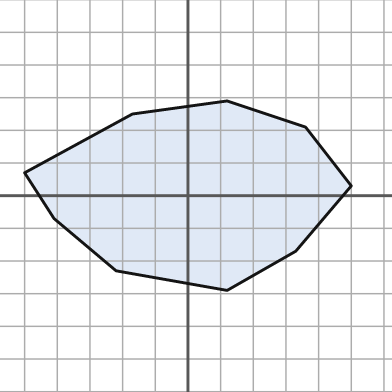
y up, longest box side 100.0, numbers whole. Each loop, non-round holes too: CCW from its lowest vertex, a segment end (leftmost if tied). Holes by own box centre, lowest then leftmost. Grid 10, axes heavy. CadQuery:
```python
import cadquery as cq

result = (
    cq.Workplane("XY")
    .moveTo(12.0, -29.0)
    .lineTo(33.0, -17.0)
    .lineTo(50.0, 3.0)
    .lineTo(36.0, 21.0)
    .lineTo(12.0, 29.0)
    .lineTo(-17.0, 25.0)
    .lineTo(-50.0, 7.0)
    .lineTo(-41.0, -7.0)
    .lineTo(-22.0, -23.0)
    .close()
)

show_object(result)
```